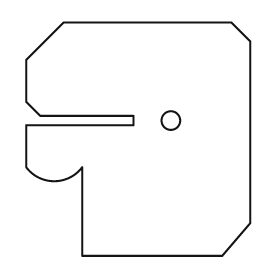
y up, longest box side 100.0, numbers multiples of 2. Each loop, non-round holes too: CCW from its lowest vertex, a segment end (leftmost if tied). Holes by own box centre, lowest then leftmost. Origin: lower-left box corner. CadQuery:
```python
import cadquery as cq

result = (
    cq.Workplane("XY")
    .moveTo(24.0, 0.0)
    .lineTo(84.0, 0.0)
    .lineTo(96.0, 14.0)
    .lineTo(96.0, 92.0)
    .lineTo(88.0, 100.0)
    .lineTo(16.0, 100.0)
    .lineTo(0.0, 84.0)
    .lineTo(0.0, 66.0)
    .lineTo(6.0, 60.0)
    .lineTo(46.0, 60.0)
    .lineTo(46.0, 56.0)
    .lineTo(0.0, 56.0)
    .lineTo(0.0, 38.0)
    .threePointArc((12.0, 32.0), (24.0, 38.0))
    .close()
    .moveTo(62.0, 58.0)
    .circle(4.0)
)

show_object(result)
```